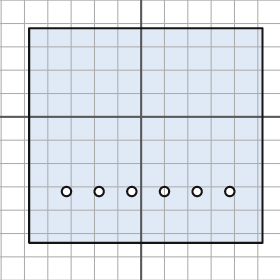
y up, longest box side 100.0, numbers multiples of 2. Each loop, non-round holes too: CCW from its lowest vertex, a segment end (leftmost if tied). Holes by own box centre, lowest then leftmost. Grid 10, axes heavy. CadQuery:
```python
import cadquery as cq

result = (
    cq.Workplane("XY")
    .moveTo(-48.0, -54.0)
    .lineTo(52.0, -54.0)
    .lineTo(52.0, 38.0)
    .lineTo(-48.0, 38.0)
    .close()
    .moveTo(-32.0, -32.0)
    .circle(2.0)
    .moveTo(-18.0, -32.0)
    .circle(2.0)
    .moveTo(-4.0, -32.0)
    .circle(2.0)
    .moveTo(10.0, -32.0)
    .circle(2.0)
    .moveTo(24.0, -32.0)
    .circle(2.0)
    .moveTo(38.0, -32.0)
    .circle(2.0)
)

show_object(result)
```